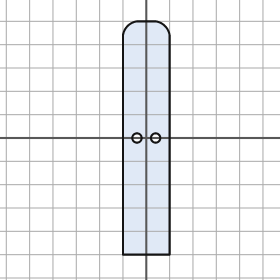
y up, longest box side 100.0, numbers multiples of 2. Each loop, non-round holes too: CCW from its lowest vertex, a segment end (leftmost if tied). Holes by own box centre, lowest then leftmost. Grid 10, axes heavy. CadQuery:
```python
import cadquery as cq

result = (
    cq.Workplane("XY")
    .moveTo(-10.0, -50.0)
    .lineTo(10.0, -50.0)
    .lineTo(10.0, 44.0)
    .threePointArc((8.0, 48.0), (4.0, 50.0))
    .lineTo(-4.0, 50.0)
    .threePointArc((-8.0, 48.0), (-10.0, 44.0))
    .close()
    .moveTo(-4.0, 0.0)
    .circle(2.0)
    .moveTo(4.0, 0.0)
    .circle(2.0)
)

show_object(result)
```